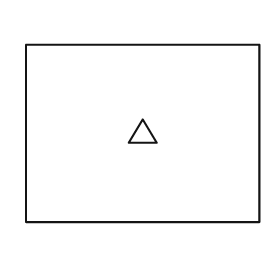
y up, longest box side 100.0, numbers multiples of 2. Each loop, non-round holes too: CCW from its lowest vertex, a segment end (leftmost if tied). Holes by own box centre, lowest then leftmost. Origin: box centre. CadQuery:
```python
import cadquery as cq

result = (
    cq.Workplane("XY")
    .moveTo(-50.0, -38.0)
    .lineTo(50.0, -38.0)
    .lineTo(50.0, 38.0)
    .lineTo(-50.0, 38.0)
    .close()
    .moveTo(-6.0, -4.0)
    .lineTo(6.0, -4.0)
    .lineTo(0.0, 6.0)
    .close()
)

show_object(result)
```